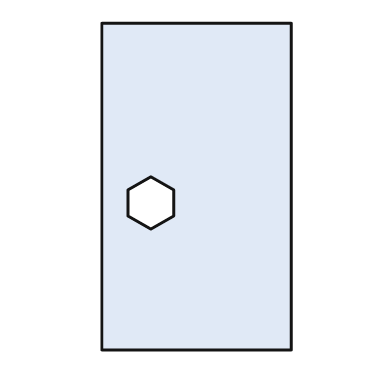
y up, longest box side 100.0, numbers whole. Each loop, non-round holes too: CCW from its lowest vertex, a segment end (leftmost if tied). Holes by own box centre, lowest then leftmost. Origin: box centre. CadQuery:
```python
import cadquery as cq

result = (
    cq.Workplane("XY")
    .moveTo(-29.0, -50.0)
    .lineTo(29.0, -50.0)
    .lineTo(29.0, 50.0)
    .lineTo(-29.0, 50.0)
    .close()
    .moveTo(-14.0, -13.0)
    .lineTo(-7.0, -9.0)
    .lineTo(-7.0, -1.0)
    .lineTo(-14.0, 3.0)
    .lineTo(-21.0, -1.0)
    .lineTo(-21.0, -9.0)
    .close()
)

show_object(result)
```